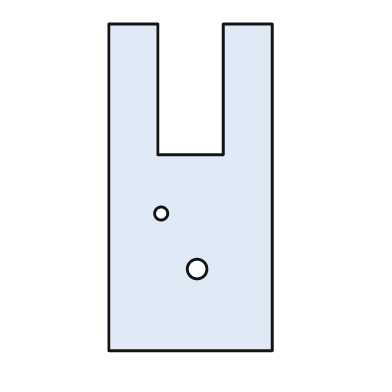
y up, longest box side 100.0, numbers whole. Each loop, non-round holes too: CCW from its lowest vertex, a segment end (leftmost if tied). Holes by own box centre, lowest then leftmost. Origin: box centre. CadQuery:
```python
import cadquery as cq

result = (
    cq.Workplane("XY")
    .moveTo(-25.0, -50.0)
    .lineTo(25.0, -50.0)
    .lineTo(25.0, 50.0)
    .lineTo(10.0, 50.0)
    .lineTo(10.0, 10.0)
    .lineTo(-10.0, 10.0)
    .lineTo(-10.0, 50.0)
    .lineTo(-25.0, 50.0)
    .close()
    .moveTo(2.0, -25.0)
    .circle(3.0)
    .moveTo(-9.0, -8.0)
    .circle(2.0)
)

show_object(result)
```